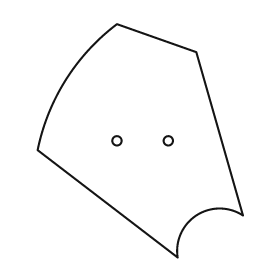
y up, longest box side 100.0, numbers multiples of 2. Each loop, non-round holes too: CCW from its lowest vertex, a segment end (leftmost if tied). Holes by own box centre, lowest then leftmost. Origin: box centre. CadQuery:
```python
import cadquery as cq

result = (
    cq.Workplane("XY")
    .moveTo(16.0, -50.0)
    .threePointArc((24.0, -32.0), (44.0, -32.0))
    .lineTo(24.0, 38.0)
    .lineTo(-10.0, 50.0)
    .threePointArc((-32.0, 26.0), (-44.0, -4.0))
    .close()
    .moveTo(-10.0, 0.0)
    .circle(2.0)
    .moveTo(12.0, 0.0)
    .circle(2.0)
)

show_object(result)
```